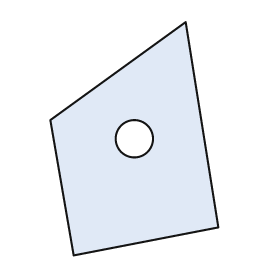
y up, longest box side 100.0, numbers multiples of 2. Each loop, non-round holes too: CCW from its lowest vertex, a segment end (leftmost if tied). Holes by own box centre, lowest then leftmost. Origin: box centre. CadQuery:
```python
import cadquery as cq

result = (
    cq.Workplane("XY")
    .moveTo(-26.0, -50.0)
    .lineTo(36.0, -38.0)
    .lineTo(22.0, 50.0)
    .lineTo(-36.0, 8.0)
    .close()
    .moveTo(0.0, 0.0)
    .circle(8.0)
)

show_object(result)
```